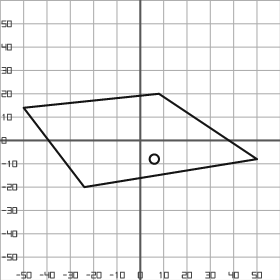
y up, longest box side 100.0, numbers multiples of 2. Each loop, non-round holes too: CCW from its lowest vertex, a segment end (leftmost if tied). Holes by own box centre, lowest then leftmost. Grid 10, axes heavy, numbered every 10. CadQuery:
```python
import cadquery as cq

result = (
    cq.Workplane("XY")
    .moveTo(-24.0, -20.0)
    .lineTo(50.0, -8.0)
    .lineTo(8.0, 20.0)
    .lineTo(-50.0, 14.0)
    .close()
    .moveTo(6.0, -8.0)
    .circle(2.0)
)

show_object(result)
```